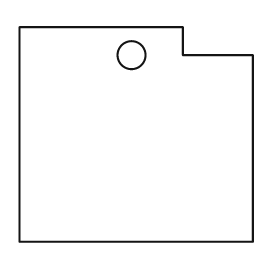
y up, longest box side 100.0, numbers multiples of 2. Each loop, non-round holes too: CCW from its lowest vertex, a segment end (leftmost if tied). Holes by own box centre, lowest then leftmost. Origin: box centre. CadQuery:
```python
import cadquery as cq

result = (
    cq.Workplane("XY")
    .moveTo(-50.0, -46.0)
    .lineTo(50.0, -46.0)
    .lineTo(50.0, 34.0)
    .lineTo(20.0, 34.0)
    .lineTo(20.0, 46.0)
    .lineTo(-50.0, 46.0)
    .close()
    .moveTo(-2.0, 34.0)
    .circle(6.0)
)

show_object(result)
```